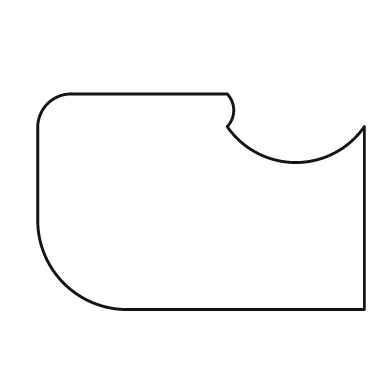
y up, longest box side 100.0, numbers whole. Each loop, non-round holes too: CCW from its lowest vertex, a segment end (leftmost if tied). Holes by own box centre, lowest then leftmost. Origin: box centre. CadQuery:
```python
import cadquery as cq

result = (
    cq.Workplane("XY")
    .moveTo(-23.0, -33.0)
    .lineTo(50.0, -33.0)
    .lineTo(50.0, 23.0)
    .threePointArc((29.0, 12.0), (8.0, 23.0))
    .threePointArc((10.0, 28.0), (8.0, 33.0))
    .lineTo(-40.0, 33.0)
    .threePointArc((-47.0, 30.0), (-50.0, 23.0))
    .lineTo(-50.0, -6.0)
    .threePointArc((-42.0, -25.0), (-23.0, -33.0))
    .close()
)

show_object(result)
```